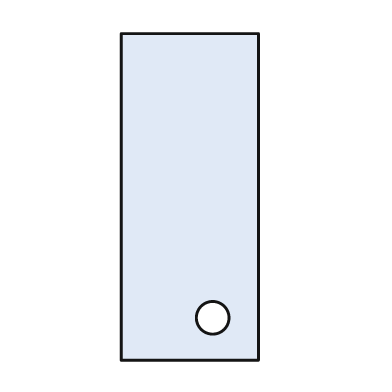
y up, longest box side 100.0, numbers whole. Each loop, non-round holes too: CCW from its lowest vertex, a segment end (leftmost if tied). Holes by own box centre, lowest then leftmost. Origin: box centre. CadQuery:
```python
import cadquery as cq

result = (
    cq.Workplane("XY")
    .moveTo(-21.0, -50.0)
    .lineTo(21.0, -50.0)
    .lineTo(21.0, 50.0)
    .lineTo(-21.0, 50.0)
    .close()
    .moveTo(7.0, -37.0)
    .circle(5.0)
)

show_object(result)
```